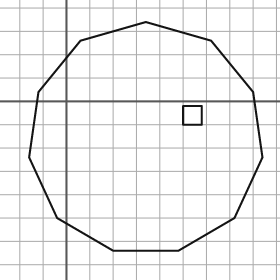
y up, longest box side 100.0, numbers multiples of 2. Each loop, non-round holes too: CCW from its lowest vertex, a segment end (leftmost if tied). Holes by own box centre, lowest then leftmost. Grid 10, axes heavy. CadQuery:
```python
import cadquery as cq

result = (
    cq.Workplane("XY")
    .moveTo(20.0, -64.0)
    .lineTo(48.0, -64.0)
    .lineTo(72.0, -50.0)
    .lineTo(84.0, -24.0)
    .lineTo(80.0, 4.0)
    .lineTo(62.0, 26.0)
    .lineTo(34.0, 34.0)
    .lineTo(6.0, 26.0)
    .lineTo(-12.0, 4.0)
    .lineTo(-16.0, -24.0)
    .lineTo(-4.0, -50.0)
    .close()
    .moveTo(50.0, -10.0)
    .lineTo(58.0, -10.0)
    .lineTo(58.0, -2.0)
    .lineTo(50.0, -2.0)
    .close()
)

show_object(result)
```